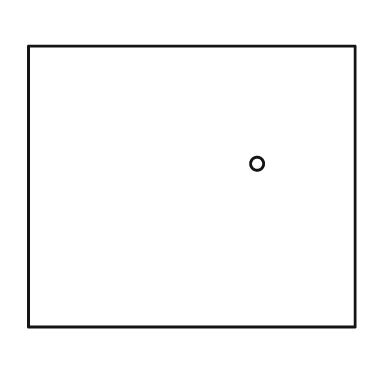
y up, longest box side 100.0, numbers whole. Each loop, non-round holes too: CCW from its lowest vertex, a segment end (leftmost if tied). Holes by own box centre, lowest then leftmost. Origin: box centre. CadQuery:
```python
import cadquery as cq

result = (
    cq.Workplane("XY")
    .moveTo(-50.0, -43.0)
    .lineTo(50.0, -43.0)
    .lineTo(50.0, 43.0)
    .lineTo(-50.0, 43.0)
    .close()
    .moveTo(20.0, 7.0)
    .circle(2.0)
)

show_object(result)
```